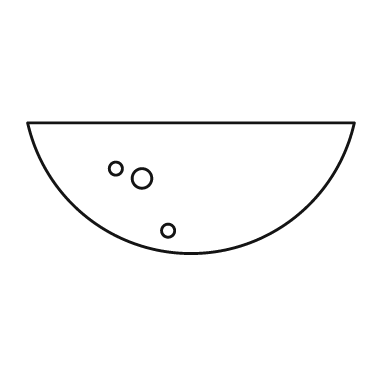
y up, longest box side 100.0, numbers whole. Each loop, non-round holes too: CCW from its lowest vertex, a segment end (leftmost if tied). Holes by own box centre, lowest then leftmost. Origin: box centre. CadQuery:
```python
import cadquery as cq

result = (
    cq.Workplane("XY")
    .moveTo(-50.0, 20.0)
    .threePointArc((0.0, -20.0), (50.0, 20.0))
    .close()
    .moveTo(-7.0, -13.0)
    .circle(2.0)
    .moveTo(-15.0, 3.0)
    .circle(3.0)
    .moveTo(-23.0, 6.0)
    .circle(2.0)
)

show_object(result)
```